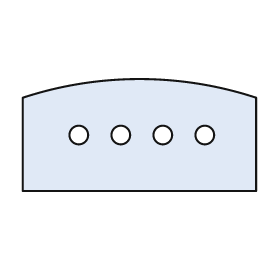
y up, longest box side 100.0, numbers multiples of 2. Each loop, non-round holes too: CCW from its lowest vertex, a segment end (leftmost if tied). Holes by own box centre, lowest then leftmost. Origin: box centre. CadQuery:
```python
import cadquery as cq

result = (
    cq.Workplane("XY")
    .moveTo(-50.0, -24.0)
    .lineTo(50.0, -24.0)
    .lineTo(50.0, 16.0)
    .threePointArc((0.0, 24.0), (-50.0, 16.0))
    .close()
    .moveTo(-26.0, 0.0)
    .circle(4.0)
    .moveTo(-8.0, 0.0)
    .circle(4.0)
    .moveTo(10.0, 0.0)
    .circle(4.0)
    .moveTo(28.0, 0.0)
    .circle(4.0)
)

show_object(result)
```